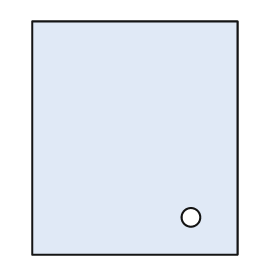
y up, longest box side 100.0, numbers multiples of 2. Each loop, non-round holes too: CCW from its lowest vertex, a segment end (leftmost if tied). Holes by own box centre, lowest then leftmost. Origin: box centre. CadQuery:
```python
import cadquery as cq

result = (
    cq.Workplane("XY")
    .moveTo(-44.0, -50.0)
    .lineTo(44.0, -50.0)
    .lineTo(44.0, 50.0)
    .lineTo(-44.0, 50.0)
    .close()
    .moveTo(24.0, -34.0)
    .circle(4.0)
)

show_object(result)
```